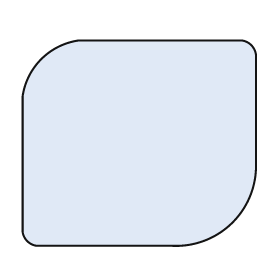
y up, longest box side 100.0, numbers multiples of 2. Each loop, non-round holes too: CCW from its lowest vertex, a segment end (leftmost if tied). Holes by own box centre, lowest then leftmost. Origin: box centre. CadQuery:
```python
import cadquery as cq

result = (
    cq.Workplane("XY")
    .moveTo(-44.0, -44.0)
    .lineTo(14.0, -44.0)
    .threePointArc((40.0, -34.0), (50.0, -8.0))
    .lineTo(50.0, 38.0)
    .threePointArc((48.0, 42.0), (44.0, 44.0))
    .lineTo(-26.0, 44.0)
    .threePointArc((-42.0, 36.0), (-50.0, 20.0))
    .lineTo(-50.0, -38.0)
    .threePointArc((-48.0, -42.0), (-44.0, -44.0))
    .close()
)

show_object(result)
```